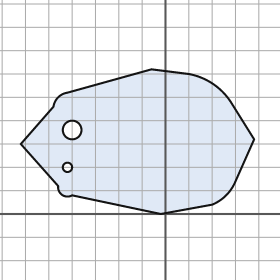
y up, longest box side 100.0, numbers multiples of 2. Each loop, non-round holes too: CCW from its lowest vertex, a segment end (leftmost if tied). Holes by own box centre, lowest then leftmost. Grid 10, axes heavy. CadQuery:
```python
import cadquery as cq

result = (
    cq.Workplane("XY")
    .moveTo(-2.0, 0.0)
    .lineTo(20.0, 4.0)
    .threePointArc((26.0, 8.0), (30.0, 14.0))
    .lineTo(38.0, 32.0)
    .lineTo(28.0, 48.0)
    .threePointArc((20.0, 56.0), (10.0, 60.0))
    .lineTo(-6.0, 62.0)
    .lineTo(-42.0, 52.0)
    .threePointArc((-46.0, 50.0), (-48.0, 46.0))
    .lineTo(-62.0, 30.0)
    .lineTo(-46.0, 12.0)
    .threePointArc((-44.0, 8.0), (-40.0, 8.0))
    .close()
    .moveTo(-42.0, 20.0)
    .circle(2.0)
    .moveTo(-40.0, 36.0)
    .circle(4.0)
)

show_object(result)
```